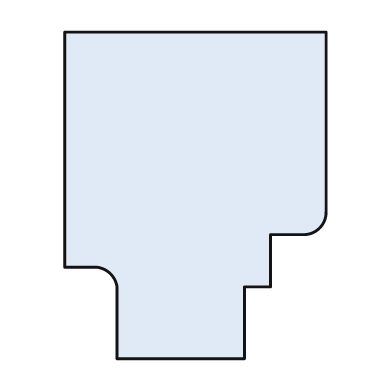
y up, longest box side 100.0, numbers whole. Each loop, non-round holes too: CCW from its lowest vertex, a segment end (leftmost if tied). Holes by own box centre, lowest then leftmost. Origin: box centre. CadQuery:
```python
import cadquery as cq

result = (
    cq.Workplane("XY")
    .moveTo(-24.0, -50.0)
    .lineTo(15.0, -50.0)
    .lineTo(15.0, -28.0)
    .lineTo(23.0, -28.0)
    .lineTo(23.0, -12.0)
    .lineTo(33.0, -12.0)
    .threePointArc((38.0, -10.0), (40.0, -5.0))
    .lineTo(40.0, 50.0)
    .lineTo(-40.0, 50.0)
    .lineTo(-40.0, -22.0)
    .lineTo(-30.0, -22.0)
    .threePointArc((-26.0, -24.0), (-24.0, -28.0))
    .close()
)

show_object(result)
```